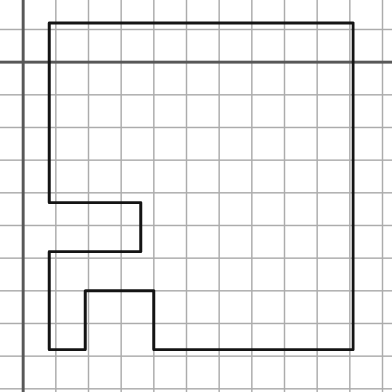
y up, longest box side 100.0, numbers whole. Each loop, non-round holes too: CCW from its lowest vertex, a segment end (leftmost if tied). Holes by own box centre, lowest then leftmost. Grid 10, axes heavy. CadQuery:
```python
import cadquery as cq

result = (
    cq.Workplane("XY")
    .moveTo(8.0, -88.0)
    .lineTo(19.0, -88.0)
    .lineTo(19.0, -70.0)
    .lineTo(40.0, -70.0)
    .lineTo(40.0, -88.0)
    .lineTo(101.0, -88.0)
    .lineTo(101.0, 12.0)
    .lineTo(8.0, 12.0)
    .lineTo(8.0, -43.0)
    .lineTo(36.0, -43.0)
    .lineTo(36.0, -58.0)
    .lineTo(8.0, -58.0)
    .close()
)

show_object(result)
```